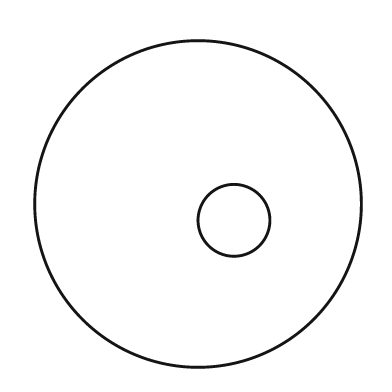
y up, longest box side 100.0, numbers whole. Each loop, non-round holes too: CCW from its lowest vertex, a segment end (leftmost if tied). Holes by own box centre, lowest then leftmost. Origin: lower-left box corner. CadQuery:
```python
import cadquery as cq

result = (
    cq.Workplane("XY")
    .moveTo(50.0, 50.0)
    .circle(50.0)
    .moveTo(61.0, 45.0)
    .circle(11.0)
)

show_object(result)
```